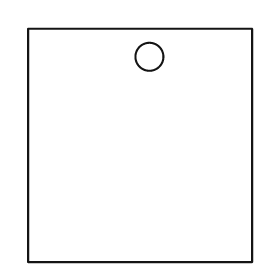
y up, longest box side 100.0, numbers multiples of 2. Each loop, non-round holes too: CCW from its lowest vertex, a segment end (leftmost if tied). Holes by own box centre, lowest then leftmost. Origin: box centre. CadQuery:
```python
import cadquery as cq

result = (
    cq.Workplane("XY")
    .moveTo(-48.0, -50.0)
    .lineTo(48.0, -50.0)
    .lineTo(48.0, 50.0)
    .lineTo(-48.0, 50.0)
    .close()
    .moveTo(4.0, 38.0)
    .circle(6.0)
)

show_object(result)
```